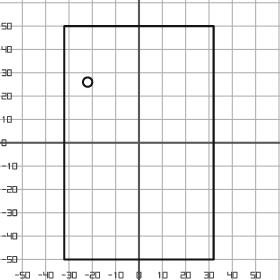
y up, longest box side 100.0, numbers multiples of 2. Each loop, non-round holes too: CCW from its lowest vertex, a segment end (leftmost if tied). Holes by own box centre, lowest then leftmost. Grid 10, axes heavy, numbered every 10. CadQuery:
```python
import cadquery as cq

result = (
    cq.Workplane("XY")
    .moveTo(-32.0, -50.0)
    .lineTo(32.0, -50.0)
    .lineTo(32.0, 50.0)
    .lineTo(-32.0, 50.0)
    .close()
    .moveTo(-22.0, 26.0)
    .circle(2.0)
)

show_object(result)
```